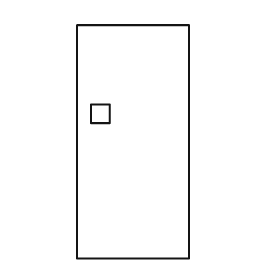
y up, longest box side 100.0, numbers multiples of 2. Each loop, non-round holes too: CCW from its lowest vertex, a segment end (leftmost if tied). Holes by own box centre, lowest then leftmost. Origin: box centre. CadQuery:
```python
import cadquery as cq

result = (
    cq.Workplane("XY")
    .moveTo(-24.0, -50.0)
    .lineTo(24.0, -50.0)
    .lineTo(24.0, 50.0)
    .lineTo(-24.0, 50.0)
    .close()
    .moveTo(-18.0, 8.0)
    .lineTo(-10.0, 8.0)
    .lineTo(-10.0, 16.0)
    .lineTo(-18.0, 16.0)
    .close()
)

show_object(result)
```